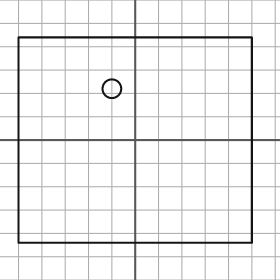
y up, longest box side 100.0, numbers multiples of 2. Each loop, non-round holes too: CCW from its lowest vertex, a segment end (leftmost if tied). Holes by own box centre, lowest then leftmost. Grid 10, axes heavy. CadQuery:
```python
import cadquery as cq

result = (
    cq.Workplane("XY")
    .moveTo(-50.0, -44.0)
    .lineTo(50.0, -44.0)
    .lineTo(50.0, 44.0)
    .lineTo(-50.0, 44.0)
    .close()
    .moveTo(-10.0, 22.0)
    .circle(4.0)
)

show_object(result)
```